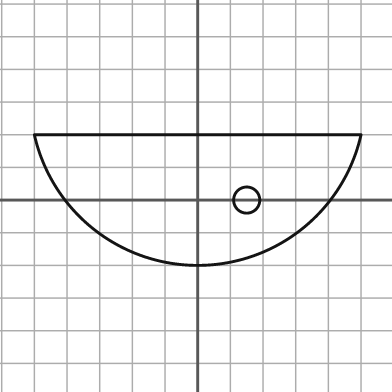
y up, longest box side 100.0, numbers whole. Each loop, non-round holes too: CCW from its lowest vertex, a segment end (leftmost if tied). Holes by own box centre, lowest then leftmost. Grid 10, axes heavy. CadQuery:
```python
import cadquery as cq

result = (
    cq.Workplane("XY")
    .moveTo(-50.0, 20.0)
    .threePointArc((0.0, -20.0), (50.0, 20.0))
    .close()
    .moveTo(15.0, 0.0)
    .circle(4.0)
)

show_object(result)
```